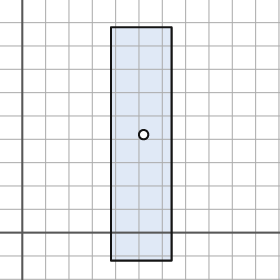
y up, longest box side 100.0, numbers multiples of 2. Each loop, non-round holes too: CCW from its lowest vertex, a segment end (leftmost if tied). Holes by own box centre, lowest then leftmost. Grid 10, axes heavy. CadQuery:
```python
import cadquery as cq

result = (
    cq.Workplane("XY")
    .moveTo(38.0, -12.0)
    .lineTo(64.0, -12.0)
    .lineTo(64.0, 88.0)
    .lineTo(38.0, 88.0)
    .close()
    .moveTo(52.0, 42.0)
    .circle(2.0)
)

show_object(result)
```